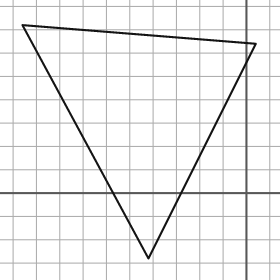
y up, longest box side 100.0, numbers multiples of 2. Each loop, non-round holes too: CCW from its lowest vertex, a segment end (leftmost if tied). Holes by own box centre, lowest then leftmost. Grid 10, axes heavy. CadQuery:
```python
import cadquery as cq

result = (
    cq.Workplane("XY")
    .moveTo(-42.0, -28.0)
    .lineTo(4.0, 64.0)
    .lineTo(-96.0, 72.0)
    .close()
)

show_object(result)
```